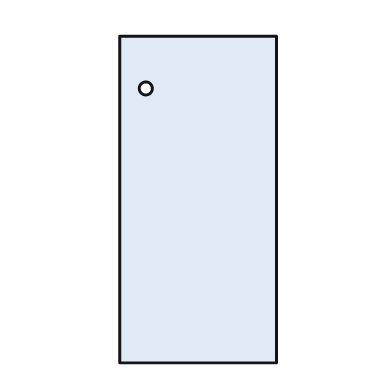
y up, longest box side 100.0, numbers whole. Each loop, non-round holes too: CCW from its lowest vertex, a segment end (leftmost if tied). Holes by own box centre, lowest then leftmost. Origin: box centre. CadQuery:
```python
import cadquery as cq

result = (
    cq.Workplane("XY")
    .moveTo(-24.0, -50.0)
    .lineTo(24.0, -50.0)
    .lineTo(24.0, 50.0)
    .lineTo(-24.0, 50.0)
    .close()
    .moveTo(-16.0, 34.0)
    .circle(2.0)
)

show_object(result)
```